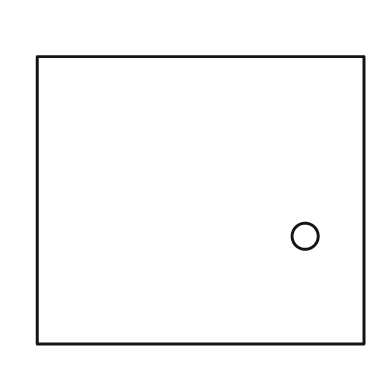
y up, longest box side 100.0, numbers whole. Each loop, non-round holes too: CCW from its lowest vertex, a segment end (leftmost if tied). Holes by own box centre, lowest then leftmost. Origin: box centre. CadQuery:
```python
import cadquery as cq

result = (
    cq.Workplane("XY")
    .moveTo(-50.0, -44.0)
    .lineTo(50.0, -44.0)
    .lineTo(50.0, 44.0)
    .lineTo(-50.0, 44.0)
    .close()
    .moveTo(32.0, -11.0)
    .circle(4.0)
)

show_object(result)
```